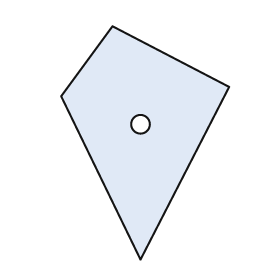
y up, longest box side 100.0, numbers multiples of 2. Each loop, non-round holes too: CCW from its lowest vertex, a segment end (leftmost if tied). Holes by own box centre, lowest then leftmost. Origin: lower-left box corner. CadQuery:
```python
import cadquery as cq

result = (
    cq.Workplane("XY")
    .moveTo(34.0, 0.0)
    .lineTo(72.0, 74.0)
    .lineTo(22.0, 100.0)
    .lineTo(0.0, 70.0)
    .close()
    .moveTo(34.0, 58.0)
    .circle(4.0)
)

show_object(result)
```